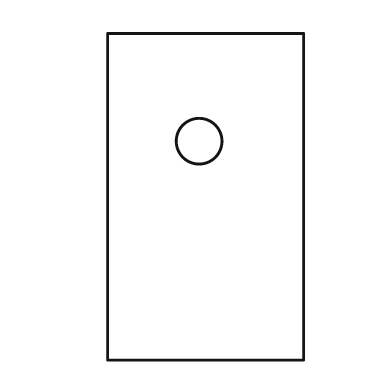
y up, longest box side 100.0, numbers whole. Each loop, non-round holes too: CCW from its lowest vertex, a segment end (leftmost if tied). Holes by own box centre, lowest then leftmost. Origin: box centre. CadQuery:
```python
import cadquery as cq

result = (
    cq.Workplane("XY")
    .moveTo(-30.0, -50.0)
    .lineTo(30.0, -50.0)
    .lineTo(30.0, 50.0)
    .lineTo(-30.0, 50.0)
    .close()
    .moveTo(-2.0, 17.0)
    .circle(7.0)
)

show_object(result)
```